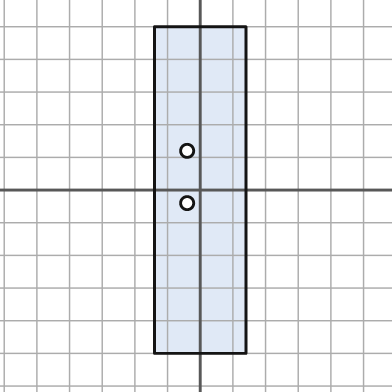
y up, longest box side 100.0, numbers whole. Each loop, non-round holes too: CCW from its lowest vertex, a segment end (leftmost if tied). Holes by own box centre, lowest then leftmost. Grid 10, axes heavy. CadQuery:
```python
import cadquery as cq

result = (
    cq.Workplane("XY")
    .moveTo(-14.0, -50.0)
    .lineTo(14.0, -50.0)
    .lineTo(14.0, 50.0)
    .lineTo(-14.0, 50.0)
    .close()
    .moveTo(-4.0, -4.0)
    .circle(2.0)
    .moveTo(-4.0, 12.0)
    .circle(2.0)
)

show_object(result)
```